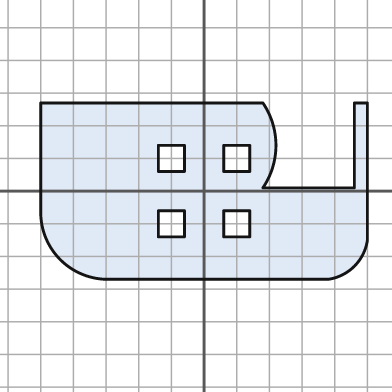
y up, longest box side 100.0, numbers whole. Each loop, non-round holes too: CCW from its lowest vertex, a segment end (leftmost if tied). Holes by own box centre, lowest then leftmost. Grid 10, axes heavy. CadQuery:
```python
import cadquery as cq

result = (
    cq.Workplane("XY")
    .moveTo(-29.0, -27.0)
    .lineTo(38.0, -27.0)
    .threePointArc((46.0, -23.0), (50.0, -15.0))
    .lineTo(50.0, 27.0)
    .lineTo(46.0, 27.0)
    .lineTo(46.0, 1.0)
    .lineTo(18.0, 1.0)
    .threePointArc((22.0, 14.0), (18.0, 27.0))
    .lineTo(-50.0, 27.0)
    .lineTo(-50.0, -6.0)
    .threePointArc((-44.0, -21.0), (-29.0, -27.0))
    .close()
    .moveTo(-14.0, -14.0)
    .lineTo(-6.0, -14.0)
    .lineTo(-6.0, -6.0)
    .lineTo(-14.0, -6.0)
    .close()
    .moveTo(6.0, -14.0)
    .lineTo(14.0, -14.0)
    .lineTo(14.0, -6.0)
    .lineTo(6.0, -6.0)
    .close()
    .moveTo(-14.0, 6.0)
    .lineTo(-6.0, 6.0)
    .lineTo(-6.0, 14.0)
    .lineTo(-14.0, 14.0)
    .close()
    .moveTo(6.0, 6.0)
    .lineTo(14.0, 6.0)
    .lineTo(14.0, 14.0)
    .lineTo(6.0, 14.0)
    .close()
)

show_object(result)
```